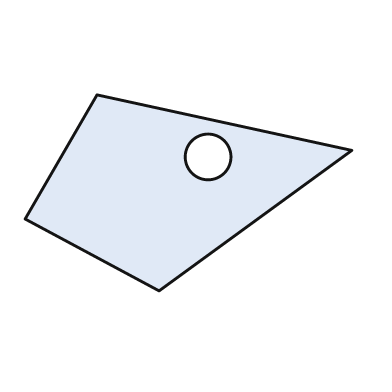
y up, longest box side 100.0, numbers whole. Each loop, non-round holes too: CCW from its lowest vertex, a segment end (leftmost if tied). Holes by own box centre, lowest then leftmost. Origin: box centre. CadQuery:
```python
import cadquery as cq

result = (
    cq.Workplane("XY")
    .moveTo(-9.0, -30.0)
    .lineTo(50.0, 13.0)
    .lineTo(-28.0, 30.0)
    .lineTo(-50.0, -8.0)
    .close()
    .moveTo(6.0, 11.0)
    .circle(7.0)
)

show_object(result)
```